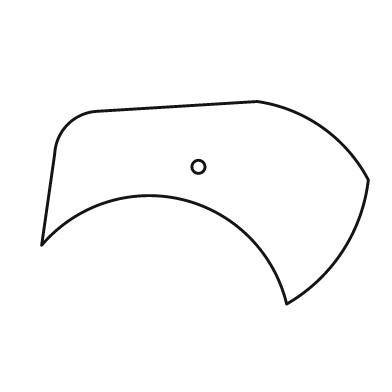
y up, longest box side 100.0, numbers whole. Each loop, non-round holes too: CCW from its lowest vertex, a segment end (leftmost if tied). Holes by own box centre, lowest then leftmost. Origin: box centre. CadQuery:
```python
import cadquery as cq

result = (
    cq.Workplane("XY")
    .moveTo(25.0, -31.0)
    .threePointArc((42.0, -15.0), (50.0, 7.0))
    .threePointArc((36.0, 23.0), (16.0, 31.0))
    .lineTo(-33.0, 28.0)
    .threePointArc((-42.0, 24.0), (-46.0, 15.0))
    .lineTo(-50.0, -13.0)
    .threePointArc((-7.0, 1.0), (25.0, -31.0))
    .close()
    .moveTo(-2.0, 11.0)
    .circle(2.0)
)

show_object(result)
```